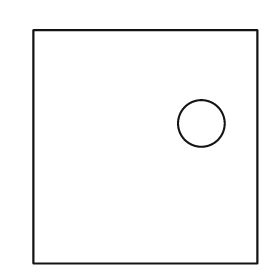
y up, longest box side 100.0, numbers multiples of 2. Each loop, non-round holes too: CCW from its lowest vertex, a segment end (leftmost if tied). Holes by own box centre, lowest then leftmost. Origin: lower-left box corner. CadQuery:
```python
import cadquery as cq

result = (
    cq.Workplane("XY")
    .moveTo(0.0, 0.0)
    .lineTo(96.0, 0.0)
    .lineTo(96.0, 100.0)
    .lineTo(0.0, 100.0)
    .close()
    .moveTo(72.0, 60.0)
    .circle(10.0)
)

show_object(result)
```